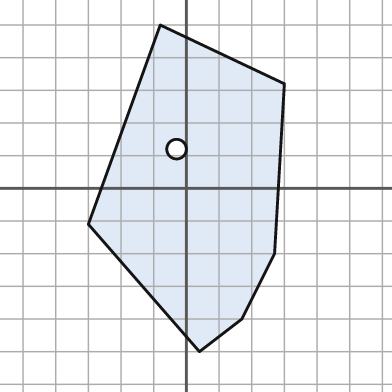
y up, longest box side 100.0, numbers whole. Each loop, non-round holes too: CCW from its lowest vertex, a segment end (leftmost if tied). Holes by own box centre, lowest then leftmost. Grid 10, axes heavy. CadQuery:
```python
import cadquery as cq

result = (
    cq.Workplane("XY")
    .moveTo(4.0, -50.0)
    .lineTo(17.0, -40.0)
    .lineTo(27.0, -20.0)
    .lineTo(30.0, 32.0)
    .lineTo(-8.0, 50.0)
    .lineTo(-30.0, -11.0)
    .close()
    .moveTo(-3.0, 12.0)
    .circle(3.0)
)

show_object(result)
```